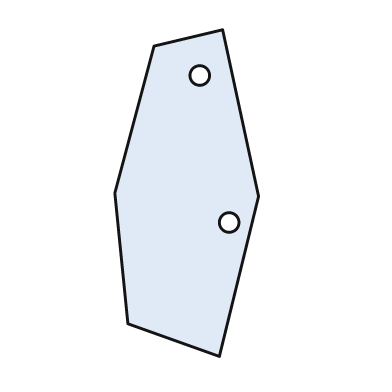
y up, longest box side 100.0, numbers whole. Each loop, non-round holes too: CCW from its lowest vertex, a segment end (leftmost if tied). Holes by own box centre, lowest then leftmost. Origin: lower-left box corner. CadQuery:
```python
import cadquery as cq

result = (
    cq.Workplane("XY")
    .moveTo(32.0, 0.0)
    .lineTo(44.0, 49.0)
    .lineTo(33.0, 100.0)
    .lineTo(12.0, 95.0)
    .lineTo(0.0, 50.0)
    .lineTo(4.0, 10.0)
    .close()
    .moveTo(35.0, 41.0)
    .circle(3.0)
    .moveTo(26.0, 86.0)
    .circle(3.0)
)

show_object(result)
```